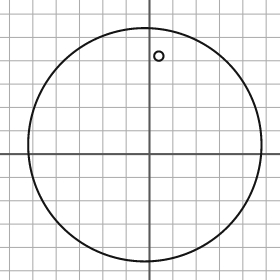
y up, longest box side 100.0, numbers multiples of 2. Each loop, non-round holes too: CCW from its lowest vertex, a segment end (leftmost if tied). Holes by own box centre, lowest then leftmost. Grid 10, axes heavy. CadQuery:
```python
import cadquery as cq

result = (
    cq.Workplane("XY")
    .moveTo(-2.0, 4.0)
    .circle(50.0)
    .moveTo(4.0, 42.0)
    .circle(2.0)
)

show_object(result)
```